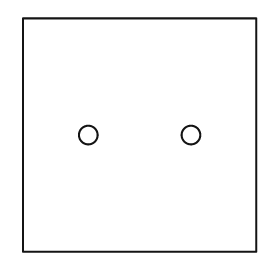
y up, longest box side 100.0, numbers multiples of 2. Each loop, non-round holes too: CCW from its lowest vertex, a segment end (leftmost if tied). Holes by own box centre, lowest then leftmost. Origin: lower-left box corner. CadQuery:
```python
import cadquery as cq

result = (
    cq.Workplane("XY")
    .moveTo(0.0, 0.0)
    .lineTo(100.0, 0.0)
    .lineTo(100.0, 100.0)
    .lineTo(0.0, 100.0)
    .close()
    .moveTo(28.0, 50.0)
    .circle(4.0)
    .moveTo(72.0, 50.0)
    .circle(4.0)
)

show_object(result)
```